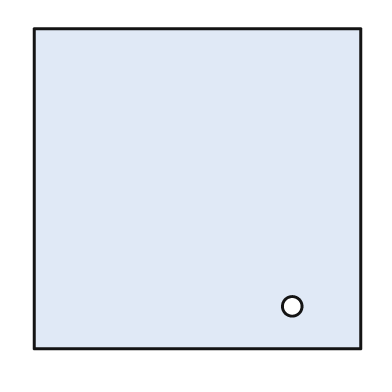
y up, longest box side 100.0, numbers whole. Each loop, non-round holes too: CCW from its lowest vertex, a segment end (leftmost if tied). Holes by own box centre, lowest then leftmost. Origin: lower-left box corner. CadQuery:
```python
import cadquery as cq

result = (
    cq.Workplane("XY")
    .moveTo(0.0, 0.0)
    .lineTo(100.0, 0.0)
    .lineTo(100.0, 98.0)
    .lineTo(0.0, 98.0)
    .close()
    .moveTo(79.0, 13.0)
    .circle(3.0)
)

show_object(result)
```